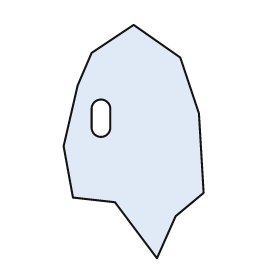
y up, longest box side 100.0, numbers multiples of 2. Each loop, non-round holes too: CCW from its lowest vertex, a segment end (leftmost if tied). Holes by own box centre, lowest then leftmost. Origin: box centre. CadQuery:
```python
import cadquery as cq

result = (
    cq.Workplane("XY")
    .moveTo(10.0, -50.0)
    .lineTo(18.0, -32.0)
    .lineTo(30.0, -22.0)
    .lineTo(28.0, 12.0)
    .lineTo(20.0, 36.0)
    .lineTo(0.0, 50.0)
    .lineTo(-18.0, 38.0)
    .lineTo(-24.0, 24.0)
    .lineTo(-30.0, -2.0)
    .lineTo(-26.0, -24.0)
    .lineTo(-8.0, -26.0)
    .close()
    .moveTo(-18.0, 6.0)
    .threePointArc((-14.0, 2.0), (-10.0, 6.0))
    .lineTo(-10.0, 14.0)
    .threePointArc((-14.0, 18.0), (-18.0, 14.0))
    .close()
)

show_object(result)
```